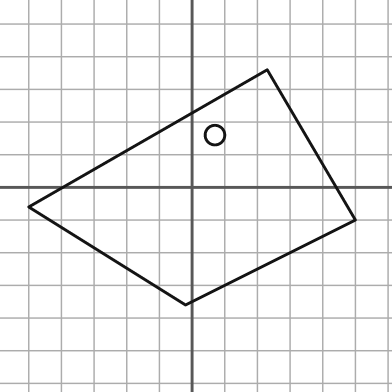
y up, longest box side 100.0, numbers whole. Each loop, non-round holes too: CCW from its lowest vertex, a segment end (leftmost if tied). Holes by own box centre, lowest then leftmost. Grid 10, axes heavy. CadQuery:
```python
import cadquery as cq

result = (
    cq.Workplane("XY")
    .moveTo(-2.0, -36.0)
    .lineTo(50.0, -10.0)
    .lineTo(23.0, 36.0)
    .lineTo(-50.0, -6.0)
    .close()
    .moveTo(7.0, 16.0)
    .circle(3.0)
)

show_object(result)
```